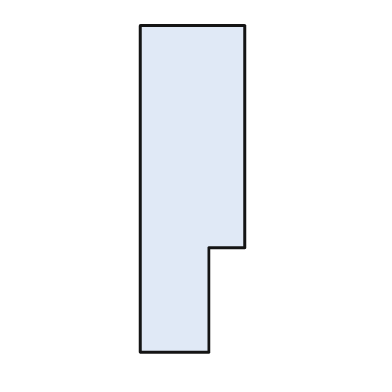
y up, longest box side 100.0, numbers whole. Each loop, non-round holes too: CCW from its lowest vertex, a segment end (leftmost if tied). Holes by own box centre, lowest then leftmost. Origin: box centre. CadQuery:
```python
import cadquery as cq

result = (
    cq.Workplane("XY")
    .moveTo(-16.0, -50.0)
    .lineTo(5.0, -50.0)
    .lineTo(5.0, -18.0)
    .lineTo(16.0, -18.0)
    .lineTo(16.0, 50.0)
    .lineTo(-16.0, 50.0)
    .close()
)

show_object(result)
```